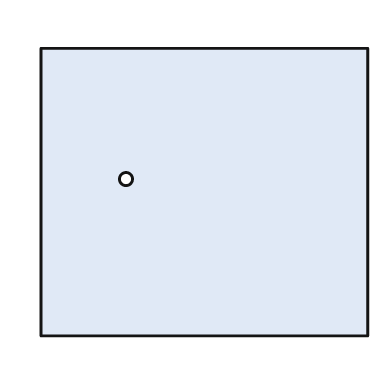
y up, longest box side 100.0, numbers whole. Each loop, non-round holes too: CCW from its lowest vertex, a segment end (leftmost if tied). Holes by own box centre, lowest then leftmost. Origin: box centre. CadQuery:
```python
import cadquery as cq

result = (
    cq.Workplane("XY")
    .moveTo(-50.0, -44.0)
    .lineTo(50.0, -44.0)
    .lineTo(50.0, 44.0)
    .lineTo(-50.0, 44.0)
    .close()
    .moveTo(-24.0, 4.0)
    .circle(2.0)
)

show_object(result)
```